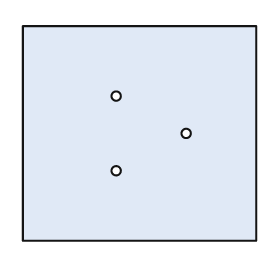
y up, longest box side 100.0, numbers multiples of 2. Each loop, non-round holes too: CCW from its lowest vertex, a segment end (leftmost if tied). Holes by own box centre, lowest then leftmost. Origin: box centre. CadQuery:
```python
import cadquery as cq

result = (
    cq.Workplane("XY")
    .moveTo(-50.0, -46.0)
    .lineTo(50.0, -46.0)
    .lineTo(50.0, 46.0)
    .lineTo(-50.0, 46.0)
    .close()
    .moveTo(-10.0, -16.0)
    .circle(2.0)
    .moveTo(20.0, 0.0)
    .circle(2.0)
    .moveTo(-10.0, 16.0)
    .circle(2.0)
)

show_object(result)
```